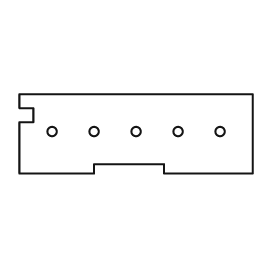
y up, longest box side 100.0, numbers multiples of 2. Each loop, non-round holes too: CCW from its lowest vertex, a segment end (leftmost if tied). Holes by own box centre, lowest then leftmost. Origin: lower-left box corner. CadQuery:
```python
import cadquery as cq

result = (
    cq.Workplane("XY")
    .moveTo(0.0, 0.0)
    .lineTo(32.0, 0.0)
    .lineTo(32.0, 4.0)
    .lineTo(62.0, 4.0)
    .lineTo(62.0, 0.0)
    .lineTo(100.0, 0.0)
    .lineTo(100.0, 34.0)
    .lineTo(0.0, 34.0)
    .lineTo(0.0, 28.0)
    .lineTo(6.0, 28.0)
    .lineTo(6.0, 22.0)
    .lineTo(0.0, 22.0)
    .close()
    .moveTo(14.0, 18.0)
    .circle(2.0)
    .moveTo(32.0, 18.0)
    .circle(2.0)
    .moveTo(50.0, 18.0)
    .circle(2.0)
    .moveTo(68.0, 18.0)
    .circle(2.0)
    .moveTo(86.0, 18.0)
    .circle(2.0)
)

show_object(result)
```